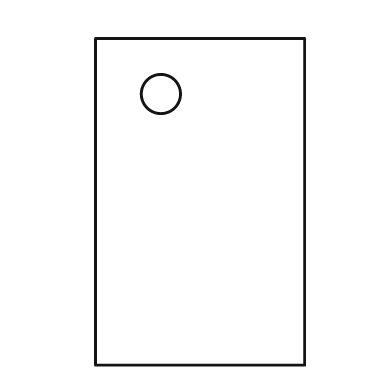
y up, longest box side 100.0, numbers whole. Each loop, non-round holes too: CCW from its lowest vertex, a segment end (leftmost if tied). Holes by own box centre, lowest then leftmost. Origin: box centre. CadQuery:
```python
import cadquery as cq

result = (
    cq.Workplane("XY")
    .moveTo(-32.0, -50.0)
    .lineTo(32.0, -50.0)
    .lineTo(32.0, 50.0)
    .lineTo(-32.0, 50.0)
    .close()
    .moveTo(-12.0, 33.0)
    .circle(6.0)
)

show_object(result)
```